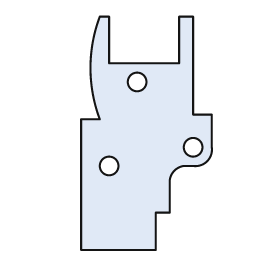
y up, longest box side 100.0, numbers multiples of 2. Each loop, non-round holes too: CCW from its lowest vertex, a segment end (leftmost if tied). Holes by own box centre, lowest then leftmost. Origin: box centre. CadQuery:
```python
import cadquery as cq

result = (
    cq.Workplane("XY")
    .moveTo(-28.0, -50.0)
    .lineTo(4.0, -50.0)
    .lineTo(4.0, -34.0)
    .lineTo(10.0, -34.0)
    .lineTo(10.0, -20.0)
    .threePointArc((12.0, -16.0), (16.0, -14.0))
    .lineTo(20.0, -14.0)
    .threePointArc((26.0, -12.0), (28.0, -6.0))
    .lineTo(28.0, 8.0)
    .lineTo(20.0, 8.0)
    .lineTo(20.0, 50.0)
    .lineTo(14.0, 50.0)
    .lineTo(14.0, 30.0)
    .lineTo(-16.0, 30.0)
    .lineTo(-16.0, 50.0)
    .lineTo(-20.0, 50.0)
    .threePointArc((-24.0, 28.0), (-20.0, 6.0))
    .lineTo(-28.0, 6.0)
    .close()
    .moveTo(-16.0, -14.0)
    .circle(4.0)
    .moveTo(20.0, -6.0)
    .circle(4.0)
    .moveTo(-4.0, 22.0)
    .circle(4.0)
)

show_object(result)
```